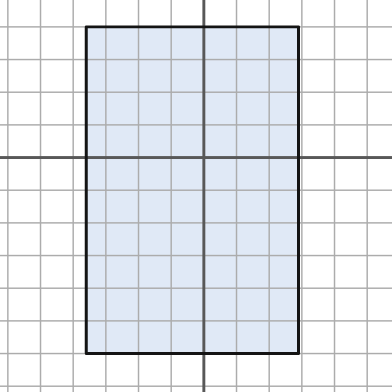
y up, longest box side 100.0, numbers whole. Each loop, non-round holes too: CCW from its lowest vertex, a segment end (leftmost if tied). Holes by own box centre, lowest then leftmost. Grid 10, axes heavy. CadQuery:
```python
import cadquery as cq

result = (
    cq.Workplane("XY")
    .moveTo(-36.0, -60.0)
    .lineTo(29.0, -60.0)
    .lineTo(29.0, 40.0)
    .lineTo(-36.0, 40.0)
    .close()
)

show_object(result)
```